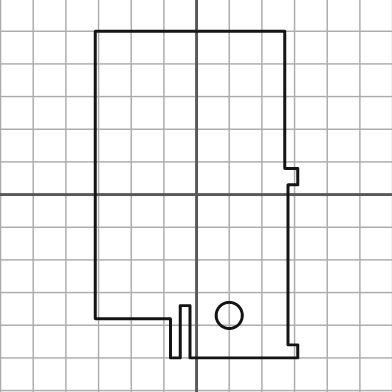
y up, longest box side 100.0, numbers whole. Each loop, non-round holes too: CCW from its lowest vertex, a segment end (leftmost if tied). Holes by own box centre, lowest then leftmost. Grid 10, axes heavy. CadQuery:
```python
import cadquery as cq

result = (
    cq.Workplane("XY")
    .moveTo(-8.0, -50.0)
    .lineTo(-5.0, -50.0)
    .lineTo(-5.0, -34.0)
    .lineTo(-2.0, -34.0)
    .lineTo(-2.0, -50.0)
    .lineTo(31.0, -50.0)
    .lineTo(31.0, -46.0)
    .lineTo(28.0, -46.0)
    .lineTo(28.0, 3.0)
    .lineTo(31.0, 3.0)
    .lineTo(31.0, 8.0)
    .lineTo(27.0, 8.0)
    .lineTo(27.0, 50.0)
    .lineTo(-31.0, 50.0)
    .lineTo(-31.0, -38.0)
    .lineTo(-8.0, -38.0)
    .close()
    .moveTo(10.0, -37.0)
    .circle(4.0)
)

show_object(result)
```